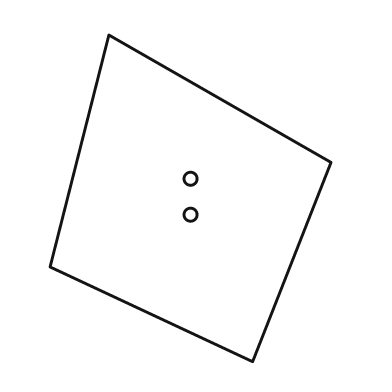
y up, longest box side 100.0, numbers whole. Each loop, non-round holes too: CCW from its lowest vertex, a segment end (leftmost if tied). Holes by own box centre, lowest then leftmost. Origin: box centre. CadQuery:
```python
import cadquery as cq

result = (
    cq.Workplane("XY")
    .moveTo(19.0, -50.0)
    .lineTo(43.0, 11.0)
    .lineTo(-25.0, 50.0)
    .lineTo(-43.0, -21.0)
    .close()
    .moveTo(0.0, -5.0)
    .circle(2.0)
    .moveTo(0.0, 6.0)
    .circle(2.0)
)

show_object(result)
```